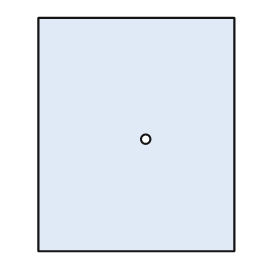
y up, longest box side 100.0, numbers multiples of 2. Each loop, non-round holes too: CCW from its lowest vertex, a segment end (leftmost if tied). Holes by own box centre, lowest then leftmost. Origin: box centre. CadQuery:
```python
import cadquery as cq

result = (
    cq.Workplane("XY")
    .moveTo(-42.0, -50.0)
    .lineTo(42.0, -50.0)
    .lineTo(42.0, 50.0)
    .lineTo(-42.0, 50.0)
    .close()
    .moveTo(4.0, -2.0)
    .circle(2.0)
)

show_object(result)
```